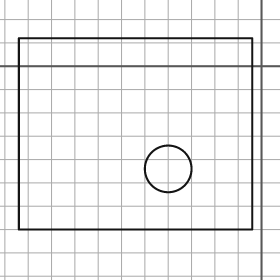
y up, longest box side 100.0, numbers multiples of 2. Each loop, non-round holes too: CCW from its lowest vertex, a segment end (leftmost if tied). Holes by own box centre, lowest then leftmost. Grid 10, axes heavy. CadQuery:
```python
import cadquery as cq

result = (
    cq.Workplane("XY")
    .moveTo(-104.0, -70.0)
    .lineTo(-4.0, -70.0)
    .lineTo(-4.0, 12.0)
    .lineTo(-104.0, 12.0)
    .close()
    .moveTo(-40.0, -44.0)
    .circle(10.0)
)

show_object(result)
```